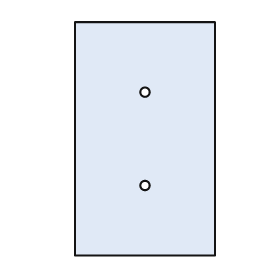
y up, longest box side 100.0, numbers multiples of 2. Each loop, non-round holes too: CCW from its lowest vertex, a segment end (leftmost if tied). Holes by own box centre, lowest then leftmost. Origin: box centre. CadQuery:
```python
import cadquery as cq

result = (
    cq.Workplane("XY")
    .moveTo(-30.0, -50.0)
    .lineTo(30.0, -50.0)
    .lineTo(30.0, 50.0)
    .lineTo(-30.0, 50.0)
    .close()
    .moveTo(0.0, -20.0)
    .circle(2.0)
    .moveTo(0.0, 20.0)
    .circle(2.0)
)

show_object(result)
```